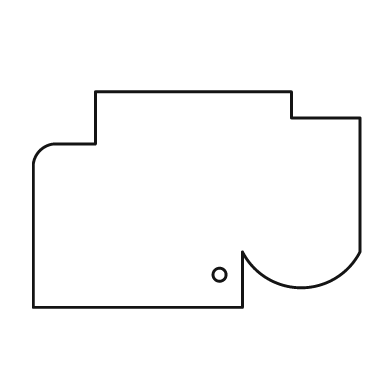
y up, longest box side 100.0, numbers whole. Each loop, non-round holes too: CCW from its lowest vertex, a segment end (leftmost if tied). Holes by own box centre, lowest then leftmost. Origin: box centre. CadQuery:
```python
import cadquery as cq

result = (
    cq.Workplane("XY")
    .moveTo(-50.0, -33.0)
    .lineTo(14.0, -33.0)
    .lineTo(14.0, -16.0)
    .threePointArc((32.0, -27.0), (50.0, -16.0))
    .lineTo(50.0, 25.0)
    .lineTo(29.0, 25.0)
    .lineTo(29.0, 33.0)
    .lineTo(-31.0, 33.0)
    .lineTo(-31.0, 17.0)
    .lineTo(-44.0, 17.0)
    .threePointArc((-48.0, 15.0), (-50.0, 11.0))
    .close()
    .moveTo(7.0, -23.0)
    .circle(2.0)
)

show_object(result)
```